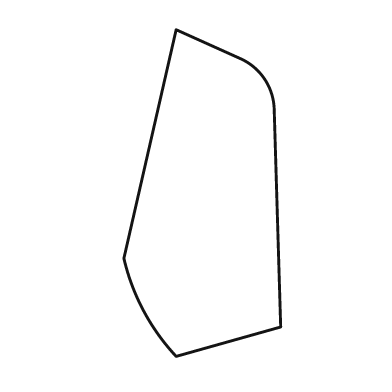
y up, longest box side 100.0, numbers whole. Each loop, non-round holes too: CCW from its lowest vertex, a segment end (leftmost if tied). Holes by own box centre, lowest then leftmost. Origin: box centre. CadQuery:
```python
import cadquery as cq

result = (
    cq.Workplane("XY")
    .moveTo(-8.0, -50.0)
    .lineTo(24.0, -41.0)
    .lineTo(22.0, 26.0)
    .threePointArc((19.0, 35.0), (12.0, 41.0))
    .lineTo(-8.0, 50.0)
    .lineTo(-24.0, -20.0)
    .threePointArc((-18.0, -36.0), (-8.0, -50.0))
    .close()
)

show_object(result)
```